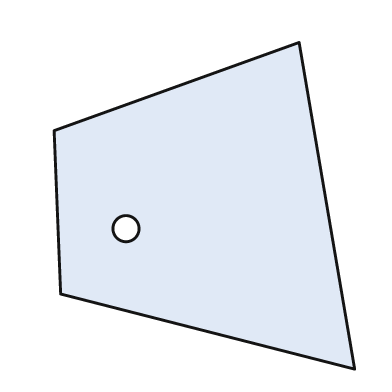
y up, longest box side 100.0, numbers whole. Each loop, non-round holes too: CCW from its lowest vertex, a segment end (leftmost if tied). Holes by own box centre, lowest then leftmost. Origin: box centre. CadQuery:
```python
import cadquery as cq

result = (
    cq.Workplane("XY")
    .moveTo(46.0, -50.0)
    .lineTo(29.0, 50.0)
    .lineTo(-46.0, 23.0)
    .lineTo(-44.0, -27.0)
    .close()
    .moveTo(-24.0, -7.0)
    .circle(4.0)
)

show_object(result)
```